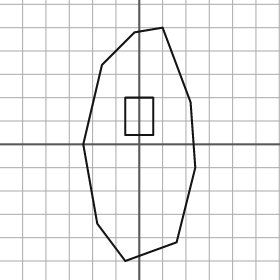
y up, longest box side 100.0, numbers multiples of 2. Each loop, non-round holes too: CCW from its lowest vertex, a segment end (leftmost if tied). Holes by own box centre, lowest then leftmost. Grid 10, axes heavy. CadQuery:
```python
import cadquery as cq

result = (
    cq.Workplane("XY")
    .moveTo(-6.0, -50.0)
    .lineTo(16.0, -42.0)
    .lineTo(24.0, -10.0)
    .lineTo(22.0, 18.0)
    .lineTo(10.0, 50.0)
    .lineTo(-2.0, 48.0)
    .lineTo(-16.0, 34.0)
    .lineTo(-24.0, 0.0)
    .lineTo(-18.0, -34.0)
    .close()
    .moveTo(-6.0, 4.0)
    .lineTo(6.0, 4.0)
    .lineTo(6.0, 20.0)
    .lineTo(-6.0, 20.0)
    .close()
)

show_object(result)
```